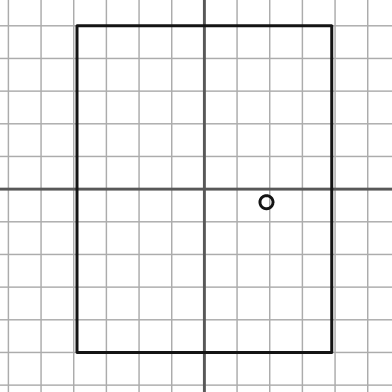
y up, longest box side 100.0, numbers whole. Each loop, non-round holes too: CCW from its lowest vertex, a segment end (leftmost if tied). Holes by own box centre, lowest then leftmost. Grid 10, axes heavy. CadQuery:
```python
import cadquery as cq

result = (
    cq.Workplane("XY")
    .moveTo(-39.0, -50.0)
    .lineTo(39.0, -50.0)
    .lineTo(39.0, 50.0)
    .lineTo(-39.0, 50.0)
    .close()
    .moveTo(19.0, -4.0)
    .circle(2.0)
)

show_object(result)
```